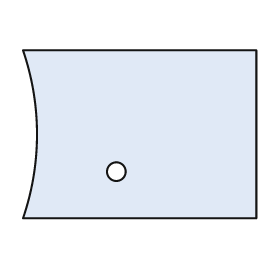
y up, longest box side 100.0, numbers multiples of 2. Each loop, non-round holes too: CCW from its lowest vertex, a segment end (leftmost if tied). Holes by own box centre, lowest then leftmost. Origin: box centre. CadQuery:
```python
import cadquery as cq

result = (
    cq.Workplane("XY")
    .moveTo(-50.0, -36.0)
    .lineTo(50.0, -36.0)
    .lineTo(50.0, 36.0)
    .lineTo(-50.0, 36.0)
    .threePointArc((-44.0, 0.0), (-50.0, -36.0))
    .close()
    .moveTo(-10.0, -16.0)
    .circle(4.0)
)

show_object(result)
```